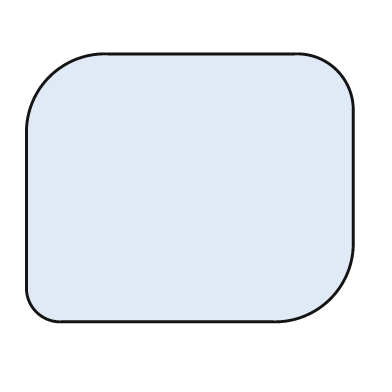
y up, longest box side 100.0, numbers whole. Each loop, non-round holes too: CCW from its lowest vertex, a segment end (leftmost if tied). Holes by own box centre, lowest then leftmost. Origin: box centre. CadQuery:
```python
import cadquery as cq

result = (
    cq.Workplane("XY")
    .moveTo(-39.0, -41.0)
    .lineTo(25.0, -41.0)
    .threePointArc((43.0, -34.0), (50.0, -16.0))
    .lineTo(50.0, 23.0)
    .threePointArc((45.0, 36.0), (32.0, 41.0))
    .lineTo(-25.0, 41.0)
    .threePointArc((-43.0, 34.0), (-50.0, 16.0))
    .lineTo(-50.0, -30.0)
    .threePointArc((-47.0, -38.0), (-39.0, -41.0))
    .close()
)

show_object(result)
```